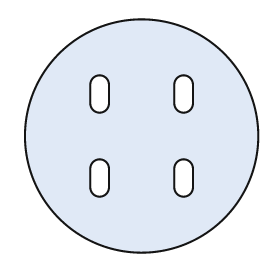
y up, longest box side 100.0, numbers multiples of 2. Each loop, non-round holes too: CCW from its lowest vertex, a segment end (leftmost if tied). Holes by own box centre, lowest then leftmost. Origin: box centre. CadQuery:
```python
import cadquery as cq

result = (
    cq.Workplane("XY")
    .moveTo(0.0, 0.0)
    .circle(50.0)
    .moveTo(-22.0, -22.0)
    .threePointArc((-18.0, -26.0), (-14.0, -22.0))
    .lineTo(-14.0, -14.0)
    .threePointArc((-18.0, -10.0), (-22.0, -14.0))
    .close()
    .moveTo(14.0, -22.0)
    .threePointArc((18.0, -26.0), (22.0, -22.0))
    .lineTo(22.0, -14.0)
    .threePointArc((18.0, -10.0), (14.0, -14.0))
    .close()
    .moveTo(-22.0, 14.0)
    .threePointArc((-18.0, 10.0), (-14.0, 14.0))
    .lineTo(-14.0, 22.0)
    .threePointArc((-18.0, 26.0), (-22.0, 22.0))
    .close()
    .moveTo(14.0, 14.0)
    .threePointArc((18.0, 10.0), (22.0, 14.0))
    .lineTo(22.0, 22.0)
    .threePointArc((18.0, 26.0), (14.0, 22.0))
    .close()
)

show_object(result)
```